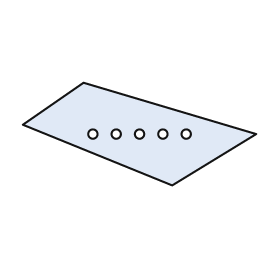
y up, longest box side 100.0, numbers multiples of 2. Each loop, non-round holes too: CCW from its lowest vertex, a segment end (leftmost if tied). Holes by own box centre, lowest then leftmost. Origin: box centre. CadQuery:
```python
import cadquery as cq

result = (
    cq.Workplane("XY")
    .moveTo(14.0, -22.0)
    .lineTo(50.0, 0.0)
    .lineTo(-24.0, 22.0)
    .lineTo(-50.0, 4.0)
    .close()
    .moveTo(-20.0, 0.0)
    .circle(2.0)
    .moveTo(-10.0, 0.0)
    .circle(2.0)
    .moveTo(0.0, 0.0)
    .circle(2.0)
    .moveTo(10.0, 0.0)
    .circle(2.0)
    .moveTo(20.0, 0.0)
    .circle(2.0)
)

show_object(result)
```